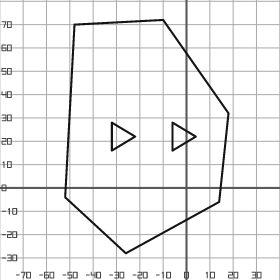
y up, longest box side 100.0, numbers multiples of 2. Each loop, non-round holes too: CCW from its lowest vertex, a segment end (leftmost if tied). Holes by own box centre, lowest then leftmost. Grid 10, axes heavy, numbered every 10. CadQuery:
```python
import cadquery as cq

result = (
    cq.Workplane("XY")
    .moveTo(-26.0, -28.0)
    .lineTo(14.0, -6.0)
    .lineTo(18.0, 32.0)
    .lineTo(-10.0, 72.0)
    .lineTo(-48.0, 70.0)
    .lineTo(-52.0, -4.0)
    .close()
    .moveTo(-32.0, 16.0)
    .lineTo(-22.0, 22.0)
    .lineTo(-32.0, 28.0)
    .close()
    .moveTo(-6.0, 16.0)
    .lineTo(4.0, 22.0)
    .lineTo(-6.0, 28.0)
    .close()
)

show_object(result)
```